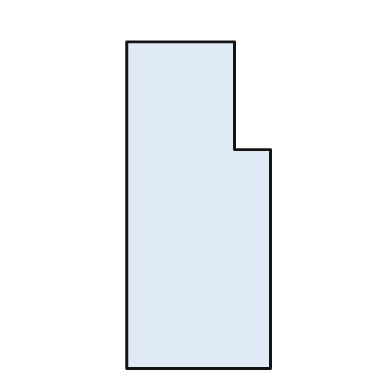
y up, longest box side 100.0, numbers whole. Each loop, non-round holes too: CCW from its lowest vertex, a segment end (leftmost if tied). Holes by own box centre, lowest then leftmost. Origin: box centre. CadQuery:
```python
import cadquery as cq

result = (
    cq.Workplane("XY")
    .moveTo(-22.0, -50.0)
    .lineTo(22.0, -50.0)
    .lineTo(22.0, 17.0)
    .lineTo(11.0, 17.0)
    .lineTo(11.0, 50.0)
    .lineTo(-22.0, 50.0)
    .close()
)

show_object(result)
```